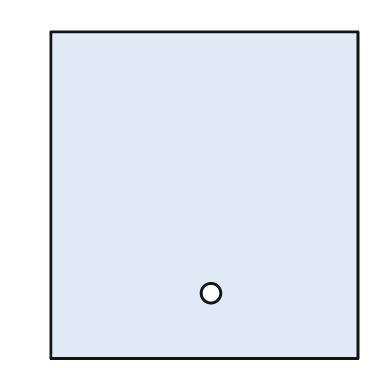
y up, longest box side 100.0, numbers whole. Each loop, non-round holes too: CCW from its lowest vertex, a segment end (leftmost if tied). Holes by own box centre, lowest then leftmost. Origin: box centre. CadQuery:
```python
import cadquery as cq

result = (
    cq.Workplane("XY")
    .moveTo(-47.0, -50.0)
    .lineTo(47.0, -50.0)
    .lineTo(47.0, 50.0)
    .lineTo(-47.0, 50.0)
    .close()
    .moveTo(2.0, -30.0)
    .circle(3.0)
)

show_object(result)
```